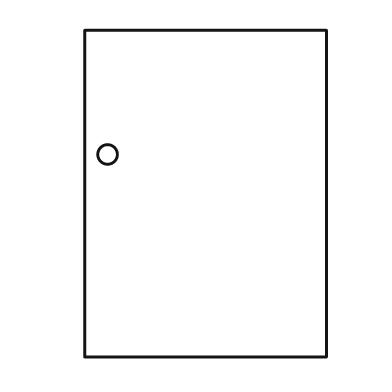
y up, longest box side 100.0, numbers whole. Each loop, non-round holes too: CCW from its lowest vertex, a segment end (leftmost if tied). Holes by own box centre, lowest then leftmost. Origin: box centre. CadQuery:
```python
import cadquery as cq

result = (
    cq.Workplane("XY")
    .moveTo(-37.0, -50.0)
    .lineTo(37.0, -50.0)
    .lineTo(37.0, 50.0)
    .lineTo(-37.0, 50.0)
    .close()
    .moveTo(-30.0, 12.0)
    .circle(3.0)
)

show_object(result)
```